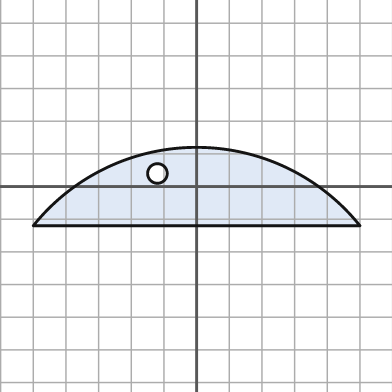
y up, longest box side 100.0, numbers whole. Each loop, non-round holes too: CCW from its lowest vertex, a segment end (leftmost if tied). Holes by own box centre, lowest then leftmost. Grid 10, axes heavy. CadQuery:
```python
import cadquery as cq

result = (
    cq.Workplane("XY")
    .moveTo(-50.0, -12.0)
    .lineTo(50.0, -12.0)
    .threePointArc((0.0, 12.0), (-50.0, -12.0))
    .close()
    .moveTo(-12.0, 4.0)
    .circle(3.0)
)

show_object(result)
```